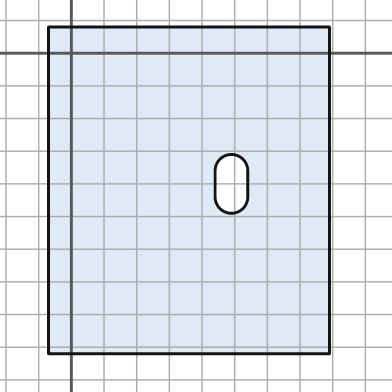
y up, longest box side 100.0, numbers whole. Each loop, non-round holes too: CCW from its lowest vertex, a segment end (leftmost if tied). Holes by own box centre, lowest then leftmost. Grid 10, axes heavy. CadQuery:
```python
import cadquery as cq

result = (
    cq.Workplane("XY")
    .moveTo(-7.0, -92.0)
    .lineTo(79.0, -92.0)
    .lineTo(79.0, 8.0)
    .lineTo(-7.0, 8.0)
    .close()
    .moveTo(44.0, -44.0)
    .threePointArc((49.0, -49.0), (54.0, -44.0))
    .lineTo(54.0, -36.0)
    .threePointArc((49.0, -31.0), (44.0, -36.0))
    .close()
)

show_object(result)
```